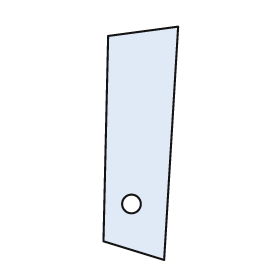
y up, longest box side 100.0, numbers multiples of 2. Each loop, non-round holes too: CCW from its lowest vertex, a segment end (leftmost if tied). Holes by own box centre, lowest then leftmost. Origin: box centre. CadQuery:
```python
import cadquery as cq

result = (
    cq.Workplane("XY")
    .moveTo(10.0, -50.0)
    .lineTo(16.0, 50.0)
    .lineTo(-14.0, 46.0)
    .lineTo(-16.0, -42.0)
    .close()
    .moveTo(-4.0, -26.0)
    .circle(4.0)
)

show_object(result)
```